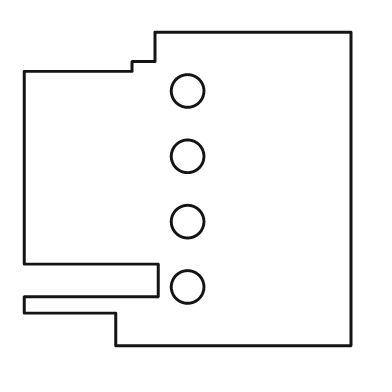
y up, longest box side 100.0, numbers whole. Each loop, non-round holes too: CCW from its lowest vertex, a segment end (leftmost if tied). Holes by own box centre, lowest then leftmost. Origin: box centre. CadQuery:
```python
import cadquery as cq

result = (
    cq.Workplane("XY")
    .moveTo(-22.0, -48.0)
    .lineTo(50.0, -48.0)
    .lineTo(50.0, 48.0)
    .lineTo(-10.0, 48.0)
    .lineTo(-10.0, 39.0)
    .lineTo(-17.0, 39.0)
    .lineTo(-17.0, 36.0)
    .lineTo(-50.0, 36.0)
    .lineTo(-50.0, -23.0)
    .lineTo(-9.0, -23.0)
    .lineTo(-9.0, -33.0)
    .lineTo(-50.0, -33.0)
    .lineTo(-50.0, -38.0)
    .lineTo(-22.0, -38.0)
    .close()
    .moveTo(0.0, -30.0)
    .circle(5.0)
    .moveTo(0.0, -10.0)
    .circle(5.0)
    .moveTo(0.0, 10.0)
    .circle(5.0)
    .moveTo(0.0, 30.0)
    .circle(5.0)
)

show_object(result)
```